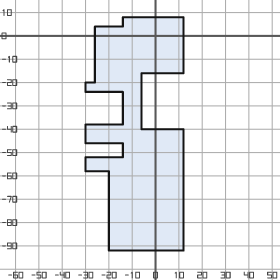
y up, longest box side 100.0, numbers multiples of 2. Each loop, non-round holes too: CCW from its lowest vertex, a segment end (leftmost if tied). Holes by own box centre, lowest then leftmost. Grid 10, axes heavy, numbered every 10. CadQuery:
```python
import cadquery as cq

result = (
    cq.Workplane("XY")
    .moveTo(-20.0, -92.0)
    .lineTo(12.0, -92.0)
    .lineTo(12.0, -40.0)
    .lineTo(-6.0, -40.0)
    .lineTo(-6.0, -16.0)
    .lineTo(12.0, -16.0)
    .lineTo(12.0, 8.0)
    .lineTo(-14.0, 8.0)
    .lineTo(-14.0, 4.0)
    .lineTo(-26.0, 4.0)
    .lineTo(-26.0, -20.0)
    .lineTo(-30.0, -20.0)
    .lineTo(-30.0, -24.0)
    .lineTo(-14.0, -24.0)
    .lineTo(-14.0, -38.0)
    .lineTo(-30.0, -38.0)
    .lineTo(-30.0, -46.0)
    .lineTo(-14.0, -46.0)
    .lineTo(-14.0, -52.0)
    .lineTo(-30.0, -52.0)
    .lineTo(-30.0, -58.0)
    .lineTo(-20.0, -58.0)
    .close()
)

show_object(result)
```